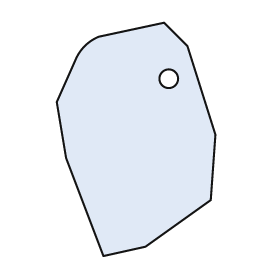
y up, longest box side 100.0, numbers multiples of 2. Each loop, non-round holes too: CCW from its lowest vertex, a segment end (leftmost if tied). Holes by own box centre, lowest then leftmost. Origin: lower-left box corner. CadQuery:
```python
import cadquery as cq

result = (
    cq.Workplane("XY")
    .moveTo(20.0, 0.0)
    .lineTo(38.0, 4.0)
    .lineTo(66.0, 24.0)
    .lineTo(68.0, 52.0)
    .lineTo(56.0, 90.0)
    .lineTo(46.0, 100.0)
    .lineTo(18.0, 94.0)
    .threePointArc((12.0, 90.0), (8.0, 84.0))
    .lineTo(0.0, 66.0)
    .lineTo(4.0, 42.0)
    .close()
    .moveTo(48.0, 76.0)
    .circle(4.0)
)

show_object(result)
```